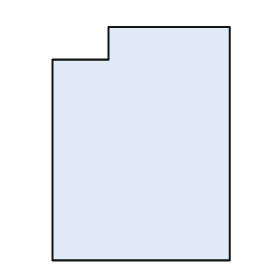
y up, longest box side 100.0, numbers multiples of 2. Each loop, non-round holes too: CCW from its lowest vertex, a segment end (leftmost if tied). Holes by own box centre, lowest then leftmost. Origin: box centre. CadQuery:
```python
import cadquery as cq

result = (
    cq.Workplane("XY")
    .moveTo(-38.0, -50.0)
    .lineTo(38.0, -50.0)
    .lineTo(38.0, 50.0)
    .lineTo(-14.0, 50.0)
    .lineTo(-14.0, 36.0)
    .lineTo(-38.0, 36.0)
    .close()
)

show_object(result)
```